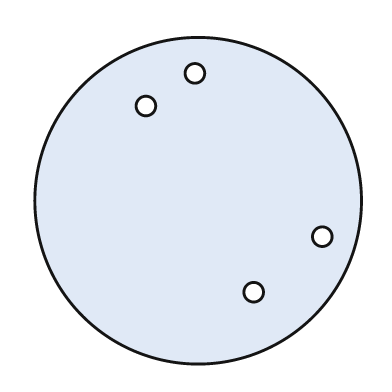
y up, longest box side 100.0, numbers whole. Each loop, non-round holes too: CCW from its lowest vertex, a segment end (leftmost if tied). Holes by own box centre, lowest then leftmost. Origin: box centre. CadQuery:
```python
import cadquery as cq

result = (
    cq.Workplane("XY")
    .moveTo(0.0, 0.0)
    .circle(50.0)
    .moveTo(17.0, -28.0)
    .circle(3.0)
    .moveTo(38.0, -11.0)
    .circle(3.0)
    .moveTo(-16.0, 29.0)
    .circle(3.0)
    .moveTo(-1.0, 39.0)
    .circle(3.0)
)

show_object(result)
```